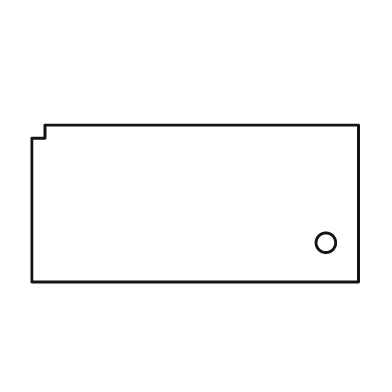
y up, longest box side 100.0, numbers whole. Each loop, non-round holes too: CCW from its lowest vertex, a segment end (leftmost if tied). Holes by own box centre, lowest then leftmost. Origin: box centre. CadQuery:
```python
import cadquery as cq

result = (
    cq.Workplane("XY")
    .moveTo(-50.0, -24.0)
    .lineTo(50.0, -24.0)
    .lineTo(50.0, 24.0)
    .lineTo(-46.0, 24.0)
    .lineTo(-46.0, 20.0)
    .lineTo(-50.0, 20.0)
    .close()
    .moveTo(40.0, -12.0)
    .circle(3.0)
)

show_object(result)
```